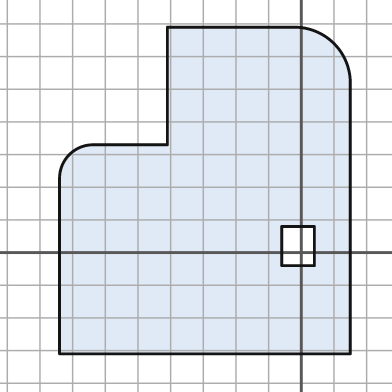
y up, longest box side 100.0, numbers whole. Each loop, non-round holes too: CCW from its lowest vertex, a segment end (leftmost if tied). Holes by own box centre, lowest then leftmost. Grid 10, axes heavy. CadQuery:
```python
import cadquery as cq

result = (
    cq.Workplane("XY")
    .moveTo(-74.0, -31.0)
    .lineTo(15.0, -31.0)
    .lineTo(15.0, 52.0)
    .threePointArc((10.0, 64.0), (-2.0, 69.0))
    .lineTo(-41.0, 69.0)
    .lineTo(-41.0, 33.0)
    .lineTo(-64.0, 33.0)
    .threePointArc((-71.0, 30.0), (-74.0, 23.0))
    .close()
    .moveTo(-6.0, -4.0)
    .lineTo(4.0, -4.0)
    .lineTo(4.0, 8.0)
    .lineTo(-6.0, 8.0)
    .close()
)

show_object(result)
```